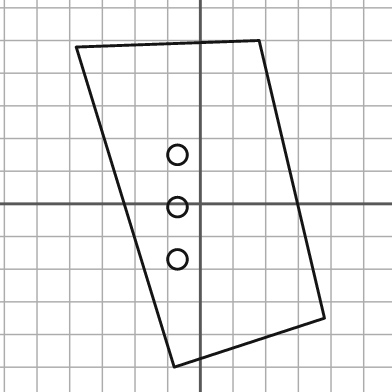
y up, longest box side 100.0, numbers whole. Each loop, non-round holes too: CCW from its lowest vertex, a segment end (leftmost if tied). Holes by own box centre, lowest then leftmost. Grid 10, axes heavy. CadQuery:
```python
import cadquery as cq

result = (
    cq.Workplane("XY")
    .moveTo(-8.0, -50.0)
    .lineTo(38.0, -35.0)
    .lineTo(18.0, 50.0)
    .lineTo(-38.0, 48.0)
    .close()
    .moveTo(-7.0, -17.0)
    .circle(3.0)
    .moveTo(-7.0, -1.0)
    .circle(3.0)
    .moveTo(-7.0, 15.0)
    .circle(3.0)
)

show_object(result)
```